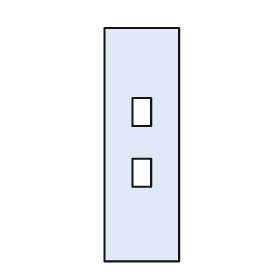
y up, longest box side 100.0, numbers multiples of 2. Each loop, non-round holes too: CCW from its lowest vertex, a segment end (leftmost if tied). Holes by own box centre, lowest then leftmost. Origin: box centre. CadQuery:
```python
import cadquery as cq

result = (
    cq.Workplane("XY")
    .moveTo(-16.0, -50.0)
    .lineTo(16.0, -50.0)
    .lineTo(16.0, 50.0)
    .lineTo(-16.0, 50.0)
    .close()
    .moveTo(-4.0, -18.0)
    .lineTo(4.0, -18.0)
    .lineTo(4.0, -6.0)
    .lineTo(-4.0, -6.0)
    .close()
    .moveTo(-4.0, 8.0)
    .lineTo(4.0, 8.0)
    .lineTo(4.0, 20.0)
    .lineTo(-4.0, 20.0)
    .close()
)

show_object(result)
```